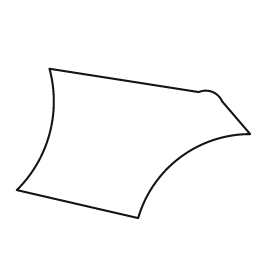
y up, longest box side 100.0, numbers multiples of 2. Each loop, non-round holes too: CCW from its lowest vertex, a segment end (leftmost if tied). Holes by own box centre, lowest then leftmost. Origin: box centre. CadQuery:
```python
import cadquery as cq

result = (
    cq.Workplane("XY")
    .moveTo(2.0, -32.0)
    .threePointArc((20.0, -6.0), (50.0, 4.0))
    .lineTo(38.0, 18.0)
    .threePointArc((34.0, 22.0), (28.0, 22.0))
    .lineTo(-36.0, 32.0)
    .threePointArc((-36.0, 4.0), (-50.0, -20.0))
    .close()
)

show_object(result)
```